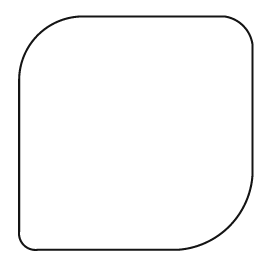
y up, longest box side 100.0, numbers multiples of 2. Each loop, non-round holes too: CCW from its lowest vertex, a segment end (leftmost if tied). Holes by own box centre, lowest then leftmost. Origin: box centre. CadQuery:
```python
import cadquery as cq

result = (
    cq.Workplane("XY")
    .moveTo(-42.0, -50.0)
    .lineTo(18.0, -50.0)
    .threePointArc((40.0, -40.0), (50.0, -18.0))
    .lineTo(50.0, 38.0)
    .threePointArc((46.0, 46.0), (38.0, 50.0))
    .lineTo(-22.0, 50.0)
    .threePointArc((-42.0, 42.0), (-50.0, 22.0))
    .lineTo(-50.0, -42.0)
    .threePointArc((-48.0, -48.0), (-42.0, -50.0))
    .close()
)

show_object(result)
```